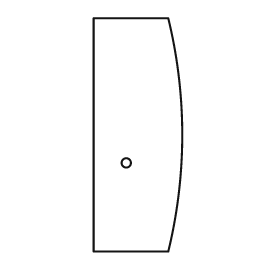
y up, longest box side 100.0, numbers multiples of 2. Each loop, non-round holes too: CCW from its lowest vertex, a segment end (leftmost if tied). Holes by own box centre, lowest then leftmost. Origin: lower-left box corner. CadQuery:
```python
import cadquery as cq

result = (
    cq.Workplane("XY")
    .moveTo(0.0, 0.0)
    .lineTo(32.0, 0.0)
    .threePointArc((38.0, 50.0), (32.0, 100.0))
    .lineTo(0.0, 100.0)
    .close()
    .moveTo(14.0, 38.0)
    .circle(2.0)
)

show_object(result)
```